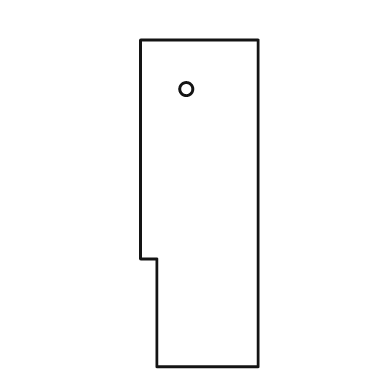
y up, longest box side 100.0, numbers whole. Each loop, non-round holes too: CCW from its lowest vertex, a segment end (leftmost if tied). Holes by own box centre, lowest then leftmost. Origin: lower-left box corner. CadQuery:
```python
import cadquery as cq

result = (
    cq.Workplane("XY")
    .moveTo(5.0, 0.0)
    .lineTo(36.0, 0.0)
    .lineTo(36.0, 100.0)
    .lineTo(0.0, 100.0)
    .lineTo(0.0, 33.0)
    .lineTo(5.0, 33.0)
    .close()
    .moveTo(14.0, 85.0)
    .circle(2.0)
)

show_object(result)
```